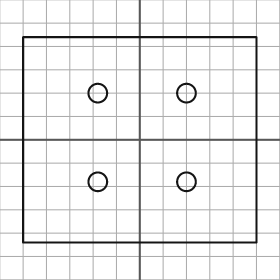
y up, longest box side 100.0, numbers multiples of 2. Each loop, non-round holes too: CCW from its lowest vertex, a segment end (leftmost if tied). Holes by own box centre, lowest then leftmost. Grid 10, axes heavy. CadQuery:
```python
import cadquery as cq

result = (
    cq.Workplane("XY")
    .moveTo(-50.0, -44.0)
    .lineTo(50.0, -44.0)
    .lineTo(50.0, 44.0)
    .lineTo(-50.0, 44.0)
    .close()
    .moveTo(-18.0, -18.0)
    .circle(4.0)
    .moveTo(20.0, -18.0)
    .circle(4.0)
    .moveTo(-18.0, 20.0)
    .circle(4.0)
    .moveTo(20.0, 20.0)
    .circle(4.0)
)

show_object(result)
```